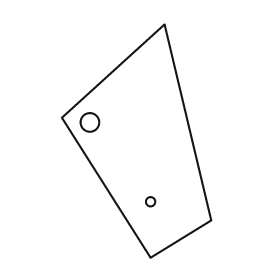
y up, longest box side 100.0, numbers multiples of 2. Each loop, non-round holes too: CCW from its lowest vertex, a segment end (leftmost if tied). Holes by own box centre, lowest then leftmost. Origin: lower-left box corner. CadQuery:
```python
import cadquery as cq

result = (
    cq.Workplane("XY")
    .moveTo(38.0, 0.0)
    .lineTo(64.0, 16.0)
    .lineTo(44.0, 100.0)
    .lineTo(0.0, 60.0)
    .close()
    .moveTo(38.0, 24.0)
    .circle(2.0)
    .moveTo(12.0, 58.0)
    .circle(4.0)
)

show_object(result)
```